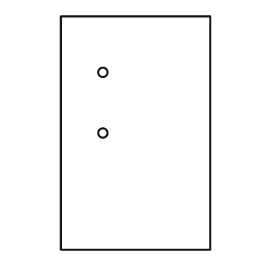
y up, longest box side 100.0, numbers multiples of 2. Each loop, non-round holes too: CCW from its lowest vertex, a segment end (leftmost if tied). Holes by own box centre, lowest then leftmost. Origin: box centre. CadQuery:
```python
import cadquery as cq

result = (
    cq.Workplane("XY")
    .moveTo(-32.0, -50.0)
    .lineTo(32.0, -50.0)
    .lineTo(32.0, 50.0)
    .lineTo(-32.0, 50.0)
    .close()
    .moveTo(-14.0, 0.0)
    .circle(2.0)
    .moveTo(-14.0, 26.0)
    .circle(2.0)
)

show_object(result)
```